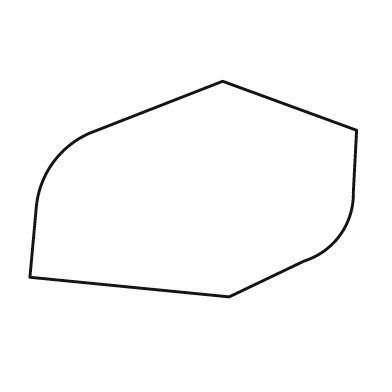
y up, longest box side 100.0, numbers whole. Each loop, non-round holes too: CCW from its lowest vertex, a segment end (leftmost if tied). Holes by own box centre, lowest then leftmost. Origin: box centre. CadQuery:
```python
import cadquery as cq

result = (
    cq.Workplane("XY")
    .moveTo(11.0, -33.0)
    .lineTo(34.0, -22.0)
    .threePointArc((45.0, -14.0), (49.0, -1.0))
    .lineTo(50.0, 18.0)
    .lineTo(9.0, 33.0)
    .lineTo(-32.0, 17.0)
    .threePointArc((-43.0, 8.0), (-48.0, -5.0))
    .lineTo(-50.0, -27.0)
    .close()
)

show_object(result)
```